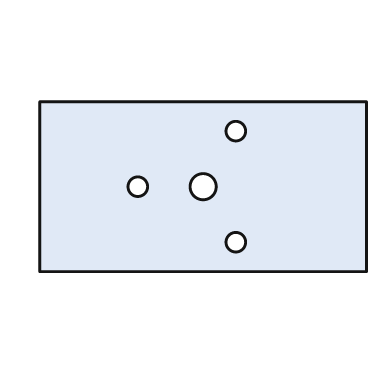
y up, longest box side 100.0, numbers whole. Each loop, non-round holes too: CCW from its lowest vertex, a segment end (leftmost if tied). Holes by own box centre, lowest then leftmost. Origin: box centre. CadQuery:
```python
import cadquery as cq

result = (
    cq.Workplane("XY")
    .moveTo(-50.0, -26.0)
    .lineTo(50.0, -26.0)
    .lineTo(50.0, 26.0)
    .lineTo(-50.0, 26.0)
    .close()
    .moveTo(10.0, -17.0)
    .circle(3.0)
    .moveTo(-20.0, 0.0)
    .circle(3.0)
    .moveTo(0.0, 0.0)
    .circle(4.0)
    .moveTo(10.0, 17.0)
    .circle(3.0)
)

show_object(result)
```